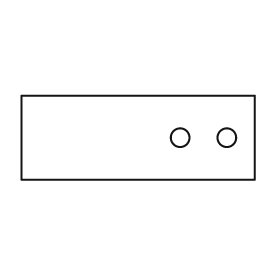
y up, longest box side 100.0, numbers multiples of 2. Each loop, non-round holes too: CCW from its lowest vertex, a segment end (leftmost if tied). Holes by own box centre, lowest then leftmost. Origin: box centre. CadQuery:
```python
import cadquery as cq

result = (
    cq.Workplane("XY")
    .moveTo(-50.0, -18.0)
    .lineTo(50.0, -18.0)
    .lineTo(50.0, 18.0)
    .lineTo(-50.0, 18.0)
    .close()
    .moveTo(18.0, 0.0)
    .circle(4.0)
    .moveTo(38.0, 0.0)
    .circle(4.0)
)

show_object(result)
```